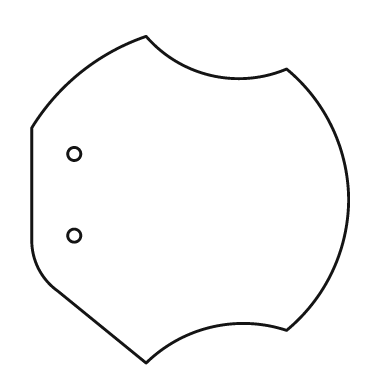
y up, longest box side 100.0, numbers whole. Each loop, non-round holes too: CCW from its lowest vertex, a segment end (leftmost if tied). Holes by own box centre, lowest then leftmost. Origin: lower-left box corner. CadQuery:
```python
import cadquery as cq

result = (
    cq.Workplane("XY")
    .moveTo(35.0, 0.0)
    .threePointArc((55.0, 11.0), (78.0, 10.0))
    .threePointArc((92.0, 28.0), (97.0, 50.0))
    .threePointArc((92.0, 72.0), (78.0, 90.0))
    .threePointArc((55.0, 88.0), (35.0, 100.0))
    .threePointArc((15.0, 89.0), (0.0, 72.0))
    .lineTo(0.0, 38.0)
    .threePointArc((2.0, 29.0), (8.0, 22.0))
    .close()
    .moveTo(13.0, 39.0)
    .circle(2.0)
    .moveTo(13.0, 64.0)
    .circle(2.0)
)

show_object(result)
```